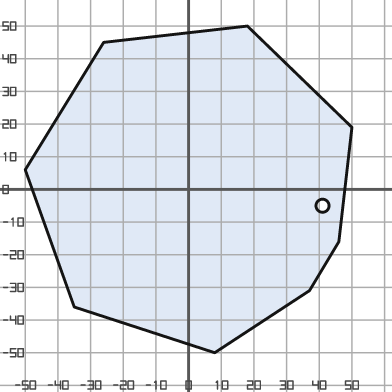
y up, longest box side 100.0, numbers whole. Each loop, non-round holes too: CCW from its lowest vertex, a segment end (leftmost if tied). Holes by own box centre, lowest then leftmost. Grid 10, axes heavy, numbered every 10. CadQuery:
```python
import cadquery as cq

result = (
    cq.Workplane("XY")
    .moveTo(8.0, -50.0)
    .lineTo(37.0, -31.0)
    .lineTo(46.0, -16.0)
    .lineTo(50.0, 19.0)
    .lineTo(18.0, 50.0)
    .lineTo(-26.0, 45.0)
    .lineTo(-50.0, 6.0)
    .lineTo(-35.0, -36.0)
    .close()
    .moveTo(41.0, -5.0)
    .circle(2.0)
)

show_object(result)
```